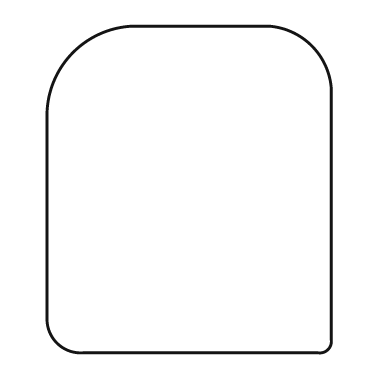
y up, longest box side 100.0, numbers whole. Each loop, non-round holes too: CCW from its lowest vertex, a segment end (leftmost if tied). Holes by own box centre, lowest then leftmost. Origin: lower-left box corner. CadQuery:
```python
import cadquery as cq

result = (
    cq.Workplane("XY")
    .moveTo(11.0, 0.0)
    .lineTo(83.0, 0.0)
    .threePointArc((86.0, 1.0), (87.0, 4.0))
    .lineTo(87.0, 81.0)
    .threePointArc((81.0, 94.0), (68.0, 100.0))
    .lineTo(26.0, 100.0)
    .threePointArc((8.0, 92.0), (0.0, 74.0))
    .lineTo(0.0, 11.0)
    .threePointArc((3.0, 3.0), (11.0, 0.0))
    .close()
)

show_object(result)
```